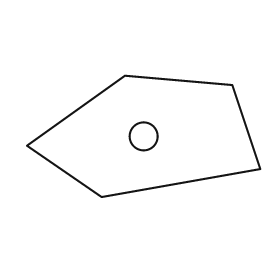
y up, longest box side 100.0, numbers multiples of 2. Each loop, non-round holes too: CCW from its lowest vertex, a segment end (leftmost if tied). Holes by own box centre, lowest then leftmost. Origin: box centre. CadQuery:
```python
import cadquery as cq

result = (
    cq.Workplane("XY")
    .moveTo(-18.0, -26.0)
    .lineTo(50.0, -14.0)
    .lineTo(38.0, 22.0)
    .lineTo(-8.0, 26.0)
    .lineTo(-50.0, -4.0)
    .close()
    .moveTo(0.0, 0.0)
    .circle(6.0)
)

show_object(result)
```